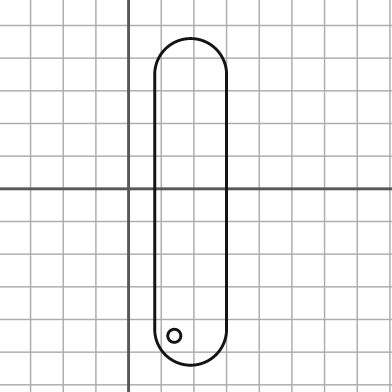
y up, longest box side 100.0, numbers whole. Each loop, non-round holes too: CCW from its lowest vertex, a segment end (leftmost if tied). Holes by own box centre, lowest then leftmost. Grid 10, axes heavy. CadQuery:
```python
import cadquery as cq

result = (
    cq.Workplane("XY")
    .moveTo(8.0, -43.0)
    .threePointArc((19.0, -54.0), (30.0, -43.0))
    .lineTo(30.0, 35.0)
    .threePointArc((19.0, 46.0), (8.0, 35.0))
    .close()
    .moveTo(14.0, -45.0)
    .circle(2.0)
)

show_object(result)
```